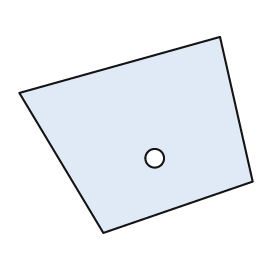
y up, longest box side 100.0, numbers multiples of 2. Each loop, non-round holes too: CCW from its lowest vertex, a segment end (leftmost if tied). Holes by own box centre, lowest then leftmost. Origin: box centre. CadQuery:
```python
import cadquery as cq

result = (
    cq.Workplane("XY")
    .moveTo(-14.0, -42.0)
    .lineTo(50.0, -20.0)
    .lineTo(36.0, 42.0)
    .lineTo(-50.0, 18.0)
    .close()
    .moveTo(8.0, -10.0)
    .circle(4.0)
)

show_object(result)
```